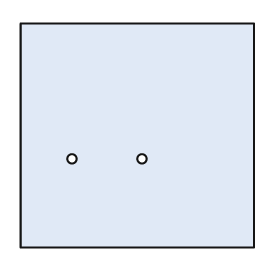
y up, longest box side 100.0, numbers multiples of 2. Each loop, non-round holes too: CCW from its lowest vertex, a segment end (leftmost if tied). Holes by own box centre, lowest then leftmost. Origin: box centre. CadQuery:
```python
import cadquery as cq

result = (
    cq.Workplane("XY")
    .moveTo(-50.0, -48.0)
    .lineTo(50.0, -48.0)
    .lineTo(50.0, 48.0)
    .lineTo(-50.0, 48.0)
    .close()
    .moveTo(-28.0, -10.0)
    .circle(2.0)
    .moveTo(2.0, -10.0)
    .circle(2.0)
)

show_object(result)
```